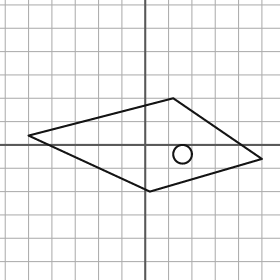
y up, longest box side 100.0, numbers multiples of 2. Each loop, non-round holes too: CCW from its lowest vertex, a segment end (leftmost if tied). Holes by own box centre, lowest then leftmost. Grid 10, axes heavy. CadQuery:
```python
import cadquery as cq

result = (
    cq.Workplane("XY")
    .moveTo(2.0, -20.0)
    .lineTo(50.0, -6.0)
    .lineTo(12.0, 20.0)
    .lineTo(-50.0, 4.0)
    .close()
    .moveTo(16.0, -4.0)
    .circle(4.0)
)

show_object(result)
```